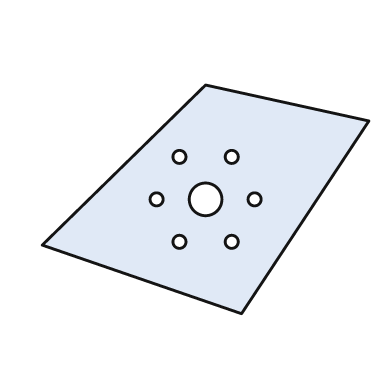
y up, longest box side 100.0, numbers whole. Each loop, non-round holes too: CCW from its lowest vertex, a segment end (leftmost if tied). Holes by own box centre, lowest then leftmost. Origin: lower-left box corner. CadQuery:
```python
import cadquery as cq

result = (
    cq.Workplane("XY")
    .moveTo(61.0, 0.0)
    .lineTo(100.0, 59.0)
    .lineTo(50.0, 70.0)
    .lineTo(0.0, 21.0)
    .close()
    .moveTo(42.0, 22.0)
    .circle(2.0)
    .moveTo(58.0, 22.0)
    .circle(2.0)
    .moveTo(35.0, 35.0)
    .circle(2.0)
    .moveTo(50.0, 35.0)
    .circle(5.0)
    .moveTo(65.0, 35.0)
    .circle(2.0)
    .moveTo(42.0, 48.0)
    .circle(2.0)
    .moveTo(58.0, 48.0)
    .circle(2.0)
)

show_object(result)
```